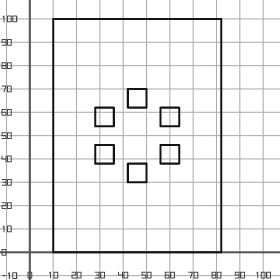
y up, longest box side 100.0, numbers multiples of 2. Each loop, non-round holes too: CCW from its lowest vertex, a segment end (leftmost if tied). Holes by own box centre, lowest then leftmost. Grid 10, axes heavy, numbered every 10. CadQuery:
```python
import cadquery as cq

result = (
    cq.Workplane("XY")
    .moveTo(10.0, 0.0)
    .lineTo(82.0, 0.0)
    .lineTo(82.0, 100.0)
    .lineTo(10.0, 100.0)
    .close()
    .moveTo(42.0, 30.0)
    .lineTo(50.0, 30.0)
    .lineTo(50.0, 38.0)
    .lineTo(42.0, 38.0)
    .close()
    .moveTo(28.0, 38.0)
    .lineTo(36.0, 38.0)
    .lineTo(36.0, 46.0)
    .lineTo(28.0, 46.0)
    .close()
    .moveTo(56.0, 38.0)
    .lineTo(64.0, 38.0)
    .lineTo(64.0, 46.0)
    .lineTo(56.0, 46.0)
    .close()
    .moveTo(28.0, 54.0)
    .lineTo(36.0, 54.0)
    .lineTo(36.0, 62.0)
    .lineTo(28.0, 62.0)
    .close()
    .moveTo(56.0, 54.0)
    .lineTo(64.0, 54.0)
    .lineTo(64.0, 62.0)
    .lineTo(56.0, 62.0)
    .close()
    .moveTo(42.0, 62.0)
    .lineTo(50.0, 62.0)
    .lineTo(50.0, 70.0)
    .lineTo(42.0, 70.0)
    .close()
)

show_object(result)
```